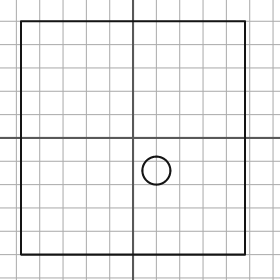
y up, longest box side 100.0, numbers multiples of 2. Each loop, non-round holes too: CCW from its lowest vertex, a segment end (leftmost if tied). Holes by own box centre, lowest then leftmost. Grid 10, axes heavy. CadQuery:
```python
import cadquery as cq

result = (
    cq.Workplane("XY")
    .moveTo(-48.0, -50.0)
    .lineTo(48.0, -50.0)
    .lineTo(48.0, 50.0)
    .lineTo(-48.0, 50.0)
    .close()
    .moveTo(10.0, -14.0)
    .circle(6.0)
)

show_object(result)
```